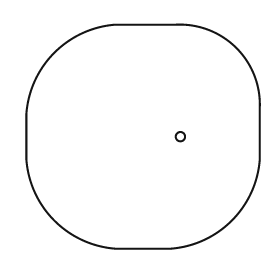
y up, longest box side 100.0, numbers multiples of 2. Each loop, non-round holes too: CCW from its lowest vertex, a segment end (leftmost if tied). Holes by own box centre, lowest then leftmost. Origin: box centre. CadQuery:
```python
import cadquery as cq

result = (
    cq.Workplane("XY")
    .moveTo(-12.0, -48.0)
    .lineTo(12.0, -48.0)
    .threePointArc((38.0, -36.0), (50.0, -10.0))
    .lineTo(50.0, 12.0)
    .threePointArc((40.0, 38.0), (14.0, 48.0))
    .lineTo(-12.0, 48.0)
    .threePointArc((-38.0, 36.0), (-50.0, 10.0))
    .lineTo(-50.0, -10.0)
    .threePointArc((-38.0, -36.0), (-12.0, -48.0))
    .close()
    .moveTo(16.0, 0.0)
    .circle(2.0)
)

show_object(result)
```